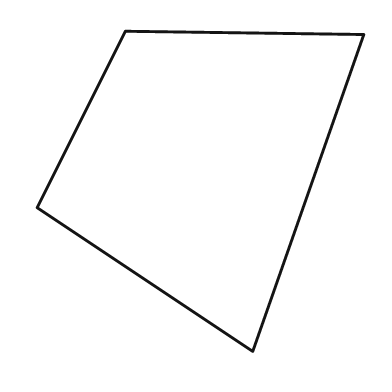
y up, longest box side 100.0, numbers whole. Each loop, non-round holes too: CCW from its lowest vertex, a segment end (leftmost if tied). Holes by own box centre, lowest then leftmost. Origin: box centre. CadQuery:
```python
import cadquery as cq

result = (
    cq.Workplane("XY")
    .moveTo(16.0, -49.0)
    .lineTo(50.0, 48.0)
    .lineTo(-23.0, 49.0)
    .lineTo(-50.0, -5.0)
    .close()
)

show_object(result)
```